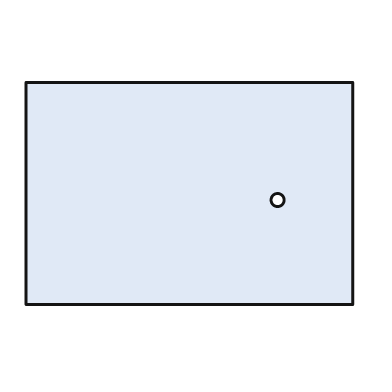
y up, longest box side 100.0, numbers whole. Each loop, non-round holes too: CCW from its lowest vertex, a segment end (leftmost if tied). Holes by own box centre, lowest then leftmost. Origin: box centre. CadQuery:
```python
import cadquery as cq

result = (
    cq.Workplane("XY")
    .moveTo(-50.0, -34.0)
    .lineTo(50.0, -34.0)
    .lineTo(50.0, 34.0)
    .lineTo(-50.0, 34.0)
    .close()
    .moveTo(27.0, -2.0)
    .circle(2.0)
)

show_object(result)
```